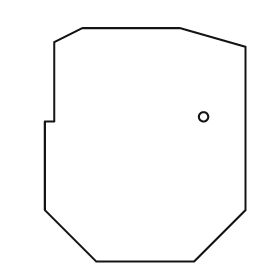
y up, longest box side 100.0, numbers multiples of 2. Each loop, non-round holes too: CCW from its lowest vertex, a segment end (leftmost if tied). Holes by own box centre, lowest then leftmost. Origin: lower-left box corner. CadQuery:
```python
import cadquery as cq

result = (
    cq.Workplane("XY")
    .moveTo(22.0, 0.0)
    .lineTo(64.0, 0.0)
    .lineTo(86.0, 22.0)
    .lineTo(86.0, 92.0)
    .lineTo(58.0, 100.0)
    .lineTo(16.0, 100.0)
    .lineTo(4.0, 94.0)
    .lineTo(4.0, 60.0)
    .lineTo(0.0, 60.0)
    .lineTo(0.0, 22.0)
    .close()
    .moveTo(68.0, 62.0)
    .circle(2.0)
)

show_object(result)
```